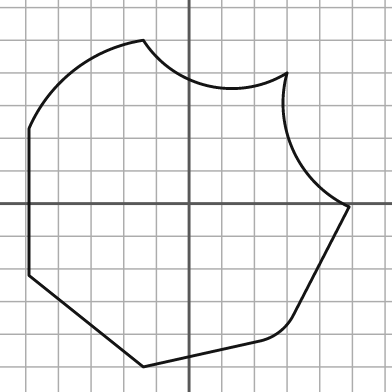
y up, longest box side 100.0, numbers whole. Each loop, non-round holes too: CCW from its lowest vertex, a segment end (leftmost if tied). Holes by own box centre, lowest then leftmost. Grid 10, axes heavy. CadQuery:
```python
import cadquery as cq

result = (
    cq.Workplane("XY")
    .moveTo(-14.0, -50.0)
    .lineTo(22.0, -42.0)
    .threePointArc((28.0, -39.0), (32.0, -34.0))
    .lineTo(49.0, -1.0)
    .threePointArc((32.0, 16.0), (30.0, 40.0))
    .threePointArc((6.0, 36.0), (-14.0, 50.0))
    .threePointArc((-35.0, 41.0), (-49.0, 23.0))
    .lineTo(-49.0, -22.0)
    .close()
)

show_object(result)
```